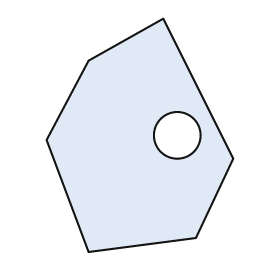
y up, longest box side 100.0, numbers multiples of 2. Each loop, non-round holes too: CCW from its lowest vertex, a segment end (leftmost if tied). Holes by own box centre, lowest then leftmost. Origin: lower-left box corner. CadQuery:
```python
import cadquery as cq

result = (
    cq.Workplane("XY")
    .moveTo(18.0, 0.0)
    .lineTo(64.0, 6.0)
    .lineTo(80.0, 40.0)
    .lineTo(50.0, 100.0)
    .lineTo(18.0, 82.0)
    .lineTo(0.0, 48.0)
    .close()
    .moveTo(56.0, 50.0)
    .circle(10.0)
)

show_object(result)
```